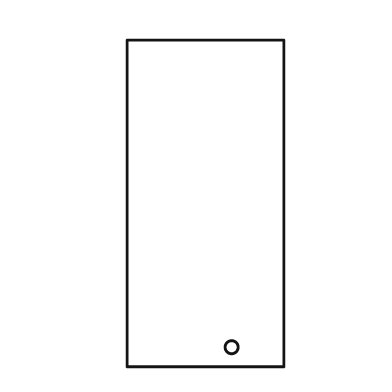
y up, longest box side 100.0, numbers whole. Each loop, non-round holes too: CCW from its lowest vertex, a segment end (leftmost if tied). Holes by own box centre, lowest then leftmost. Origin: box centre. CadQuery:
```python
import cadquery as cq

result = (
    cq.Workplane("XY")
    .moveTo(-24.0, -50.0)
    .lineTo(24.0, -50.0)
    .lineTo(24.0, 50.0)
    .lineTo(-24.0, 50.0)
    .close()
    .moveTo(8.0, -44.0)
    .circle(2.0)
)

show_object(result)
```